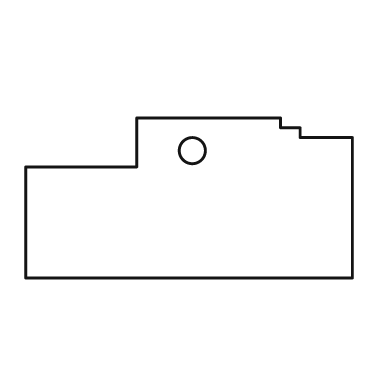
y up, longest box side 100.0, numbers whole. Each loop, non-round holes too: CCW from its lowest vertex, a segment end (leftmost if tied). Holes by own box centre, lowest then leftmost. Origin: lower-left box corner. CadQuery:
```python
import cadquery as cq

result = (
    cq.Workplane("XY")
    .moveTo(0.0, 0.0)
    .lineTo(100.0, 0.0)
    .lineTo(100.0, 43.0)
    .lineTo(84.0, 43.0)
    .lineTo(84.0, 46.0)
    .lineTo(78.0, 46.0)
    .lineTo(78.0, 49.0)
    .lineTo(34.0, 49.0)
    .lineTo(34.0, 34.0)
    .lineTo(0.0, 34.0)
    .close()
    .moveTo(51.0, 39.0)
    .circle(4.0)
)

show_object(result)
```